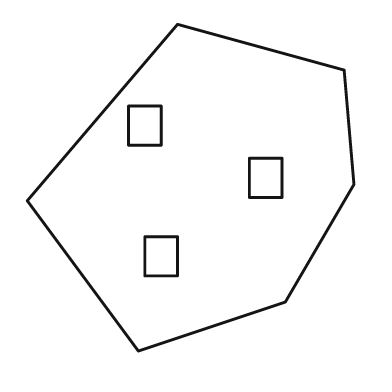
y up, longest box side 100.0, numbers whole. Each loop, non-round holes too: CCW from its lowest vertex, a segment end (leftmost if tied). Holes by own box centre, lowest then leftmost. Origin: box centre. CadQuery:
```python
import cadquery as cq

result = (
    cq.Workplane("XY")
    .moveTo(-16.0, -50.0)
    .lineTo(29.0, -35.0)
    .lineTo(50.0, 1.0)
    .lineTo(47.0, 36.0)
    .lineTo(-4.0, 50.0)
    .lineTo(-50.0, -4.0)
    .close()
    .moveTo(-14.0, -27.0)
    .lineTo(-4.0, -27.0)
    .lineTo(-4.0, -15.0)
    .lineTo(-14.0, -15.0)
    .close()
    .moveTo(18.0, -3.0)
    .lineTo(28.0, -3.0)
    .lineTo(28.0, 9.0)
    .lineTo(18.0, 9.0)
    .close()
    .moveTo(-19.0, 13.0)
    .lineTo(-9.0, 13.0)
    .lineTo(-9.0, 25.0)
    .lineTo(-19.0, 25.0)
    .close()
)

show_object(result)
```